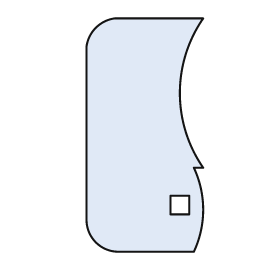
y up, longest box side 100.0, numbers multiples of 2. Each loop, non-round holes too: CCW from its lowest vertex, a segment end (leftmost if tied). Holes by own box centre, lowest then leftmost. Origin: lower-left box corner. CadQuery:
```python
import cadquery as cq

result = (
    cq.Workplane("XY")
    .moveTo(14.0, 0.0)
    .lineTo(46.0, 0.0)
    .threePointArc((50.0, 18.0), (46.0, 36.0))
    .lineTo(50.0, 36.0)
    .threePointArc((40.0, 68.0), (50.0, 100.0))
    .lineTo(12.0, 100.0)
    .threePointArc((4.0, 96.0), (0.0, 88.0))
    .lineTo(0.0, 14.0)
    .threePointArc((4.0, 4.0), (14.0, 0.0))
    .close()
    .moveTo(36.0, 16.0)
    .lineTo(44.0, 16.0)
    .lineTo(44.0, 24.0)
    .lineTo(36.0, 24.0)
    .close()
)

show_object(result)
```